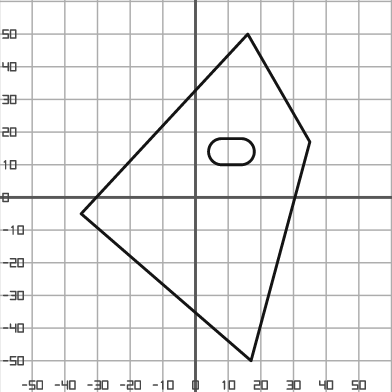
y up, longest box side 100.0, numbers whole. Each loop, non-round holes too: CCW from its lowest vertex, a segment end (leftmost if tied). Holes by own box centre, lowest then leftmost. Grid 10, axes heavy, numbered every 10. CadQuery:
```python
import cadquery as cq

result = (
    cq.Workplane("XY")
    .moveTo(17.0, -50.0)
    .lineTo(35.0, 17.0)
    .lineTo(16.0, 50.0)
    .lineTo(-35.0, -5.0)
    .close()
    .moveTo(8.0, 10.0)
    .lineTo(14.0, 10.0)
    .threePointArc((18.0, 14.0), (14.0, 18.0))
    .lineTo(8.0, 18.0)
    .threePointArc((4.0, 14.0), (8.0, 10.0))
    .close()
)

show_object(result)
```